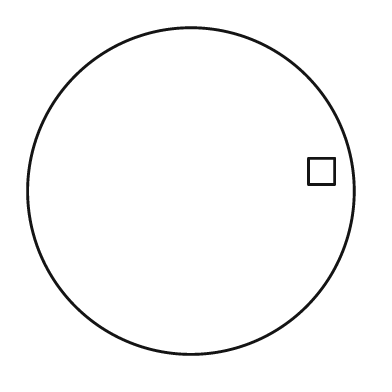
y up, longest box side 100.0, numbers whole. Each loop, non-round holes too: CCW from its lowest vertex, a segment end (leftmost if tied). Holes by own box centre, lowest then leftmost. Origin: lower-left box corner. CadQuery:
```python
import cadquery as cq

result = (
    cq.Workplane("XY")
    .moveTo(50.0, 50.0)
    .circle(50.0)
    .moveTo(86.0, 52.0)
    .lineTo(94.0, 52.0)
    .lineTo(94.0, 60.0)
    .lineTo(86.0, 60.0)
    .close()
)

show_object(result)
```